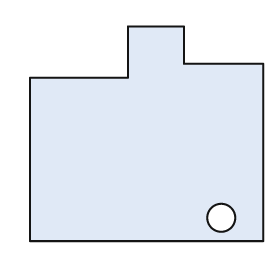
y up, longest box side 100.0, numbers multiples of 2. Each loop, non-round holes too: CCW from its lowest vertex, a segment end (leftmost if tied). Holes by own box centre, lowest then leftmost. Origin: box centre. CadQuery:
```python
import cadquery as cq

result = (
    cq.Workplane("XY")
    .moveTo(-50.0, -46.0)
    .lineTo(50.0, -46.0)
    .lineTo(50.0, 30.0)
    .lineTo(16.0, 30.0)
    .lineTo(16.0, 46.0)
    .lineTo(-8.0, 46.0)
    .lineTo(-8.0, 24.0)
    .lineTo(-50.0, 24.0)
    .close()
    .moveTo(32.0, -36.0)
    .circle(6.0)
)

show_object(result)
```